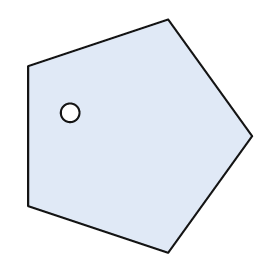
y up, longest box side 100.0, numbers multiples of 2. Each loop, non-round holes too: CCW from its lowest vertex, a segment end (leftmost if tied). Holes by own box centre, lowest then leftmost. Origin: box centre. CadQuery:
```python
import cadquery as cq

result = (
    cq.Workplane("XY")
    .moveTo(12.0, -50.0)
    .lineTo(48.0, 0.0)
    .lineTo(12.0, 50.0)
    .lineTo(-48.0, 30.0)
    .lineTo(-48.0, -30.0)
    .close()
    .moveTo(-30.0, 10.0)
    .circle(4.0)
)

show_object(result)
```